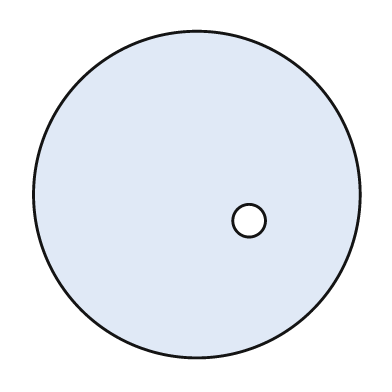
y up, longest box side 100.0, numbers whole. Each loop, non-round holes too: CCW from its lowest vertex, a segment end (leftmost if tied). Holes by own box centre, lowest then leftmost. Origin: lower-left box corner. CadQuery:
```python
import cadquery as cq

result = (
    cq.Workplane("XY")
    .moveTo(50.0, 50.0)
    .circle(50.0)
    .moveTo(66.0, 42.0)
    .circle(5.0)
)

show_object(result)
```